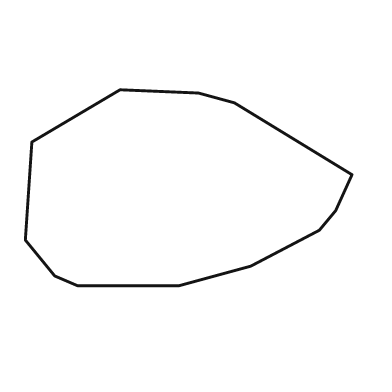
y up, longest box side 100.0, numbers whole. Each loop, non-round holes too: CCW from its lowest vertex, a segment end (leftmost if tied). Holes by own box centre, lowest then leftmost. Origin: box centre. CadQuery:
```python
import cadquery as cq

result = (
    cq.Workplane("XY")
    .moveTo(-34.0, -30.0)
    .lineTo(-3.0, -30.0)
    .lineTo(19.0, -24.0)
    .lineTo(40.0, -13.0)
    .lineTo(45.0, -7.0)
    .lineTo(50.0, 4.0)
    .lineTo(14.0, 26.0)
    .lineTo(3.0, 29.0)
    .lineTo(-21.0, 30.0)
    .lineTo(-48.0, 14.0)
    .lineTo(-50.0, -16.0)
    .lineTo(-41.0, -27.0)
    .close()
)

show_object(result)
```